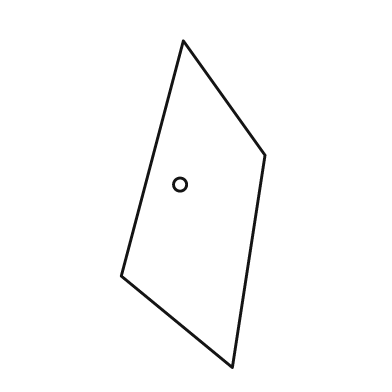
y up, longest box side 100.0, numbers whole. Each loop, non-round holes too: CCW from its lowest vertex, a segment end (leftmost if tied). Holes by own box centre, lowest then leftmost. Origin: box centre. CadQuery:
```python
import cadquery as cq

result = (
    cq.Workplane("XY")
    .moveTo(12.0, -50.0)
    .lineTo(22.0, 15.0)
    .lineTo(-3.0, 50.0)
    .lineTo(-22.0, -22.0)
    .close()
    .moveTo(-4.0, 6.0)
    .circle(2.0)
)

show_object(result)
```